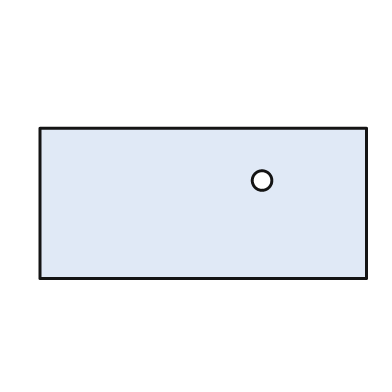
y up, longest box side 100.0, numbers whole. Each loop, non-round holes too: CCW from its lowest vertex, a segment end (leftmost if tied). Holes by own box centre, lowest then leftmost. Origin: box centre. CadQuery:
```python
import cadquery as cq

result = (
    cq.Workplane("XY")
    .moveTo(-50.0, -23.0)
    .lineTo(50.0, -23.0)
    .lineTo(50.0, 23.0)
    .lineTo(-50.0, 23.0)
    .close()
    .moveTo(18.0, 7.0)
    .circle(3.0)
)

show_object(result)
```